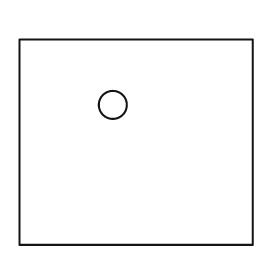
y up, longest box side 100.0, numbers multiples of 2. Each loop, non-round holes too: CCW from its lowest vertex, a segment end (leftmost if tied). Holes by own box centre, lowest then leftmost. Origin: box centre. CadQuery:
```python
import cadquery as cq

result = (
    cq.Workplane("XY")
    .moveTo(-50.0, -44.0)
    .lineTo(50.0, -44.0)
    .lineTo(50.0, 44.0)
    .lineTo(-50.0, 44.0)
    .close()
    .moveTo(-10.0, 16.0)
    .circle(6.0)
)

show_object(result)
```